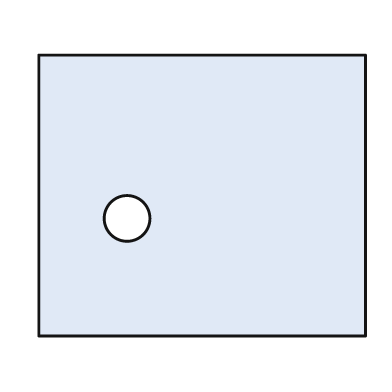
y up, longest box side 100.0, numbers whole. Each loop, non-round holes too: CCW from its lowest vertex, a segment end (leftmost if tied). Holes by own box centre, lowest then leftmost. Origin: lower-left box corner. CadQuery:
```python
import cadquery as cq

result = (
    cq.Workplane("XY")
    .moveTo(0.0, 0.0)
    .lineTo(100.0, 0.0)
    .lineTo(100.0, 86.0)
    .lineTo(0.0, 86.0)
    .close()
    .moveTo(27.0, 36.0)
    .circle(7.0)
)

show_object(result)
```